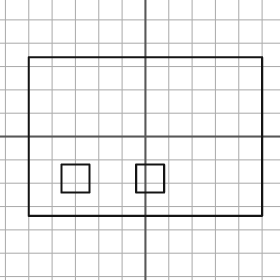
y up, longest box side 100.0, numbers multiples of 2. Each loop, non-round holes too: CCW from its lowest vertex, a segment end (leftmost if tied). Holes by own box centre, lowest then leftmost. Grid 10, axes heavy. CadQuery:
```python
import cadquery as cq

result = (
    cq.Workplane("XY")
    .moveTo(-50.0, -34.0)
    .lineTo(50.0, -34.0)
    .lineTo(50.0, 34.0)
    .lineTo(-50.0, 34.0)
    .close()
    .moveTo(-36.0, -24.0)
    .lineTo(-24.0, -24.0)
    .lineTo(-24.0, -12.0)
    .lineTo(-36.0, -12.0)
    .close()
    .moveTo(-4.0, -24.0)
    .lineTo(8.0, -24.0)
    .lineTo(8.0, -12.0)
    .lineTo(-4.0, -12.0)
    .close()
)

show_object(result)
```